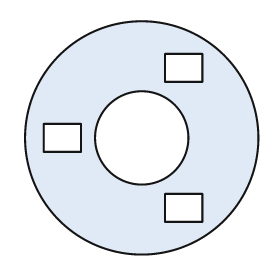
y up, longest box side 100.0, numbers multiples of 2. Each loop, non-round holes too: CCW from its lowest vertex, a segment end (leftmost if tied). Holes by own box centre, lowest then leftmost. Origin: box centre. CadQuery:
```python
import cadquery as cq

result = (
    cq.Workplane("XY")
    .moveTo(0.0, 0.0)
    .circle(50.0)
    .moveTo(10.0, -36.0)
    .lineTo(26.0, -36.0)
    .lineTo(26.0, -24.0)
    .lineTo(10.0, -24.0)
    .close()
    .moveTo(-42.0, -6.0)
    .lineTo(-26.0, -6.0)
    .lineTo(-26.0, 6.0)
    .lineTo(-42.0, 6.0)
    .close()
    .moveTo(0.0, 0.0)
    .circle(20.0)
    .moveTo(10.0, 24.0)
    .lineTo(26.0, 24.0)
    .lineTo(26.0, 36.0)
    .lineTo(10.0, 36.0)
    .close()
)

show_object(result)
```